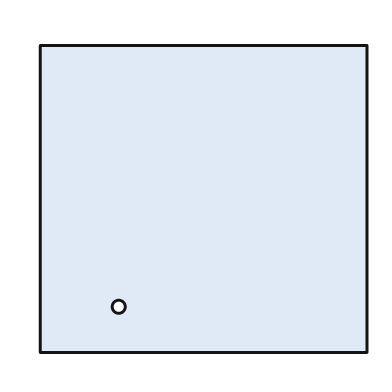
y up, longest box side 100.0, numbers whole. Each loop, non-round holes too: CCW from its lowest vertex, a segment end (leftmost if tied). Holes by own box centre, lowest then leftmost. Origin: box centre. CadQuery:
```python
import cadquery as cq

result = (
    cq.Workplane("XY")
    .moveTo(-50.0, -47.0)
    .lineTo(50.0, -47.0)
    .lineTo(50.0, 47.0)
    .lineTo(-50.0, 47.0)
    .close()
    .moveTo(-26.0, -33.0)
    .circle(2.0)
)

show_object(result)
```